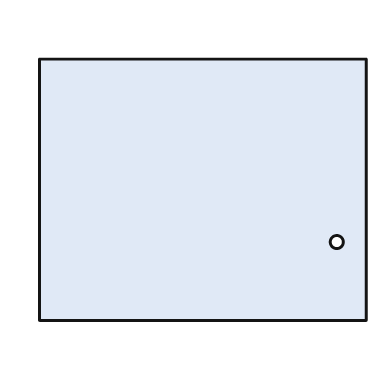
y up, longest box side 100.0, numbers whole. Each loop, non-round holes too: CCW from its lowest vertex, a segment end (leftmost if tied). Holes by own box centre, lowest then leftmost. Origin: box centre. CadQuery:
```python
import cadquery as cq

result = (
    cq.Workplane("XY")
    .moveTo(-50.0, -40.0)
    .lineTo(50.0, -40.0)
    .lineTo(50.0, 40.0)
    .lineTo(-50.0, 40.0)
    .close()
    .moveTo(41.0, -16.0)
    .circle(2.0)
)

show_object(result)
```